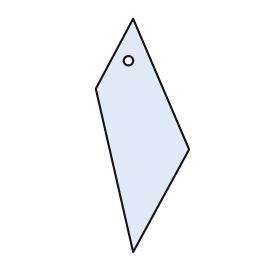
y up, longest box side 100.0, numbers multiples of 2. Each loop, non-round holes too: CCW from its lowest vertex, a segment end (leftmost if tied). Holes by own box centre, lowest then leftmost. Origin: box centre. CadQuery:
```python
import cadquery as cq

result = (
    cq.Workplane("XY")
    .moveTo(-4.0, -50.0)
    .lineTo(20.0, -6.0)
    .lineTo(-4.0, 50.0)
    .lineTo(-20.0, 20.0)
    .close()
    .moveTo(-6.0, 32.0)
    .circle(2.0)
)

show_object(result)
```